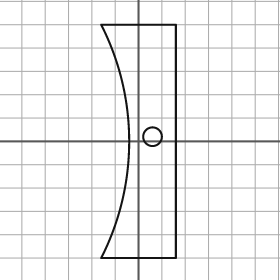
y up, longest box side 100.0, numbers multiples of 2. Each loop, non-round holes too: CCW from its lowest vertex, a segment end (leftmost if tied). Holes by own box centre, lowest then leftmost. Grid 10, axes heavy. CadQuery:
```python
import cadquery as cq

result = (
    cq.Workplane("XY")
    .moveTo(-16.0, -50.0)
    .lineTo(16.0, -50.0)
    .lineTo(16.0, 50.0)
    .lineTo(-16.0, 50.0)
    .threePointArc((-4.0, 0.0), (-16.0, -50.0))
    .close()
    .moveTo(6.0, 2.0)
    .circle(4.0)
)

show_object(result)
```